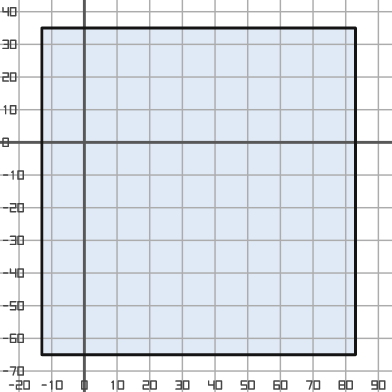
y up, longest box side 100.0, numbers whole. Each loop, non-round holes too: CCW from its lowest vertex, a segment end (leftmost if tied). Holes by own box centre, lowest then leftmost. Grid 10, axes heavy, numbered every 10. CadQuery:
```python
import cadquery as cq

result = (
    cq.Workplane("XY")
    .moveTo(-13.0, -65.0)
    .lineTo(83.0, -65.0)
    .lineTo(83.0, 35.0)
    .lineTo(-13.0, 35.0)
    .close()
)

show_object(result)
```